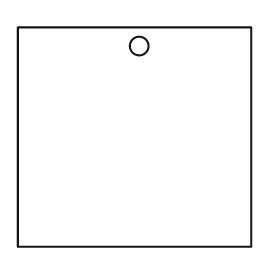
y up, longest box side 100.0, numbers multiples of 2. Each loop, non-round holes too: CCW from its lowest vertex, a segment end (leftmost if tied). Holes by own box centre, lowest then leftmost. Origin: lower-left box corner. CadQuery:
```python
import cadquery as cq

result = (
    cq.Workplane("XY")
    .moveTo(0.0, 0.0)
    .lineTo(100.0, 0.0)
    .lineTo(100.0, 94.0)
    .lineTo(0.0, 94.0)
    .close()
    .moveTo(52.0, 86.0)
    .circle(4.0)
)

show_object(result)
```